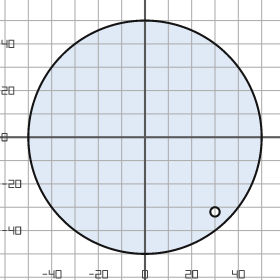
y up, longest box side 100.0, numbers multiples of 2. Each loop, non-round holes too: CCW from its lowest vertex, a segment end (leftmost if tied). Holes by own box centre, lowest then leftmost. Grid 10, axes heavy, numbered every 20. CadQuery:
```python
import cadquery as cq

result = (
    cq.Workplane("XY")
    .moveTo(0.0, 0.0)
    .circle(50.0)
    .moveTo(30.0, -32.0)
    .circle(2.0)
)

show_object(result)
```